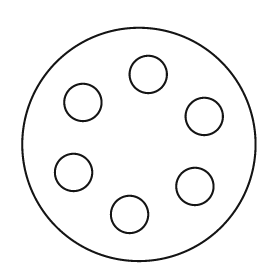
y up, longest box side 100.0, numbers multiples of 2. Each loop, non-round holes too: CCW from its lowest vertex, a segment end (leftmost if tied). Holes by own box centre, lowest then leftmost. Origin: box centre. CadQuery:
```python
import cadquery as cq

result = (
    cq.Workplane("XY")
    .moveTo(0.0, 0.0)
    .circle(50.0)
    .moveTo(-4.0, -30.0)
    .circle(8.0)
    .moveTo(24.0, -18.0)
    .circle(8.0)
    .moveTo(-28.0, -12.0)
    .circle(8.0)
    .moveTo(28.0, 12.0)
    .circle(8.0)
    .moveTo(-24.0, 18.0)
    .circle(8.0)
    .moveTo(4.0, 30.0)
    .circle(8.0)
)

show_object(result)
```